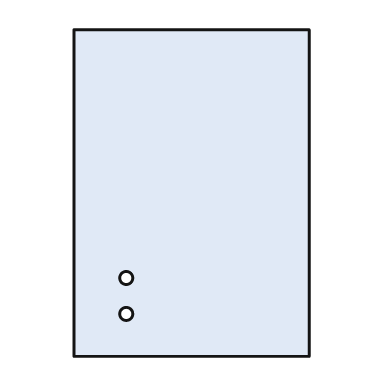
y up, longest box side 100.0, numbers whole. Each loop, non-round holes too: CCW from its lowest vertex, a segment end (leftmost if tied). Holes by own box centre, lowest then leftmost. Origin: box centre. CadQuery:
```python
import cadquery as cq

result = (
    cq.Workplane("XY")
    .moveTo(-36.0, -50.0)
    .lineTo(36.0, -50.0)
    .lineTo(36.0, 50.0)
    .lineTo(-36.0, 50.0)
    .close()
    .moveTo(-20.0, -37.0)
    .circle(2.0)
    .moveTo(-20.0, -26.0)
    .circle(2.0)
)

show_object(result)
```